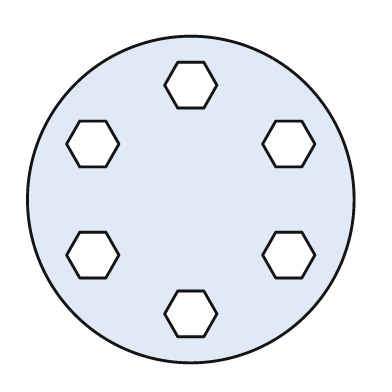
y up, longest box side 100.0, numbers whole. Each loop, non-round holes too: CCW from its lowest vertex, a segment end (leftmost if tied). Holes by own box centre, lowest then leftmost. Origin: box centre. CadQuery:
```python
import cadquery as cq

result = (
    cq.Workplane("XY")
    .moveTo(0.0, 0.0)
    .circle(50.0)
    .moveTo(-4.0, -42.0)
    .lineTo(4.0, -42.0)
    .lineTo(8.0, -35.0)
    .lineTo(4.0, -28.0)
    .lineTo(-4.0, -28.0)
    .lineTo(-8.0, -35.0)
    .close()
    .moveTo(-34.0, -24.0)
    .lineTo(-26.0, -24.0)
    .lineTo(-22.0, -17.0)
    .lineTo(-26.0, -10.0)
    .lineTo(-34.0, -10.0)
    .lineTo(-38.0, -17.0)
    .close()
    .moveTo(26.0, -24.0)
    .lineTo(34.0, -24.0)
    .lineTo(38.0, -17.0)
    .lineTo(34.0, -10.0)
    .lineTo(26.0, -10.0)
    .lineTo(22.0, -17.0)
    .close()
    .moveTo(-34.0, 10.0)
    .lineTo(-26.0, 10.0)
    .lineTo(-22.0, 17.0)
    .lineTo(-26.0, 24.0)
    .lineTo(-34.0, 24.0)
    .lineTo(-38.0, 17.0)
    .close()
    .moveTo(26.0, 10.0)
    .lineTo(34.0, 10.0)
    .lineTo(38.0, 17.0)
    .lineTo(34.0, 24.0)
    .lineTo(26.0, 24.0)
    .lineTo(22.0, 17.0)
    .close()
    .moveTo(-4.0, 28.0)
    .lineTo(4.0, 28.0)
    .lineTo(8.0, 35.0)
    .lineTo(4.0, 42.0)
    .lineTo(-4.0, 42.0)
    .lineTo(-8.0, 35.0)
    .close()
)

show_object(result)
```